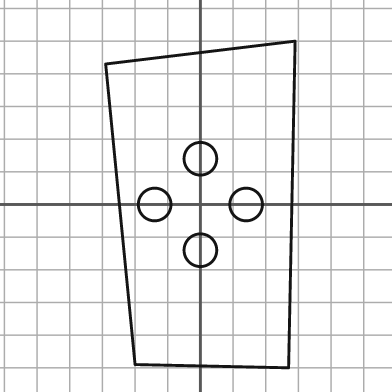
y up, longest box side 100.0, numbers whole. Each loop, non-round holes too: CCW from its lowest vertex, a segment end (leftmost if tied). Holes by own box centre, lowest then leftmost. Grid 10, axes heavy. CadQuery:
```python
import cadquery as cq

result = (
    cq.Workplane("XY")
    .moveTo(27.0, -50.0)
    .lineTo(29.0, 50.0)
    .lineTo(-29.0, 43.0)
    .lineTo(-20.0, -49.0)
    .close()
    .moveTo(0.0, -14.0)
    .circle(5.0)
    .moveTo(-14.0, 0.0)
    .circle(5.0)
    .moveTo(14.0, 0.0)
    .circle(5.0)
    .moveTo(0.0, 14.0)
    .circle(5.0)
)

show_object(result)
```